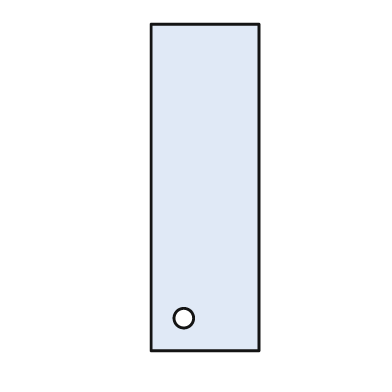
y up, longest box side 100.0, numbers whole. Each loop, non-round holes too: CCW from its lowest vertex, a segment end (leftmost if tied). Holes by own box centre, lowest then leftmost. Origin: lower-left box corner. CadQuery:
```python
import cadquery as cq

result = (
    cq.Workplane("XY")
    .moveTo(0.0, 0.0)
    .lineTo(33.0, 0.0)
    .lineTo(33.0, 100.0)
    .lineTo(0.0, 100.0)
    .close()
    .moveTo(10.0, 10.0)
    .circle(3.0)
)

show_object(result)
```